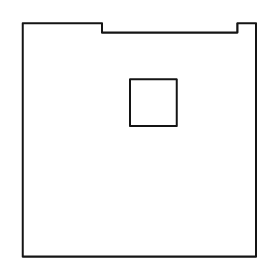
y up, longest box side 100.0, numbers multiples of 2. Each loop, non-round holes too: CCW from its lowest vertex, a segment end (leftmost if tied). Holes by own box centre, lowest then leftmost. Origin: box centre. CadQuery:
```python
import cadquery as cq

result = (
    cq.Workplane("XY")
    .moveTo(-50.0, -50.0)
    .lineTo(50.0, -50.0)
    .lineTo(50.0, 50.0)
    .lineTo(42.0, 50.0)
    .lineTo(42.0, 46.0)
    .lineTo(-16.0, 46.0)
    .lineTo(-16.0, 50.0)
    .lineTo(-50.0, 50.0)
    .close()
    .moveTo(-4.0, 6.0)
    .lineTo(16.0, 6.0)
    .lineTo(16.0, 26.0)
    .lineTo(-4.0, 26.0)
    .close()
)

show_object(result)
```